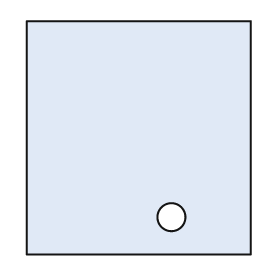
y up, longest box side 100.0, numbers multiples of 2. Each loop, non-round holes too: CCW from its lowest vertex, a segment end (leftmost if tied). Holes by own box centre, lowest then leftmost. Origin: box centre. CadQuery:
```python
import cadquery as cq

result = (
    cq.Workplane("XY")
    .moveTo(-48.0, -50.0)
    .lineTo(48.0, -50.0)
    .lineTo(48.0, 50.0)
    .lineTo(-48.0, 50.0)
    .close()
    .moveTo(14.0, -34.0)
    .circle(6.0)
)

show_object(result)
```